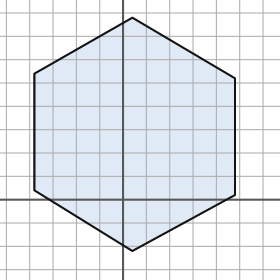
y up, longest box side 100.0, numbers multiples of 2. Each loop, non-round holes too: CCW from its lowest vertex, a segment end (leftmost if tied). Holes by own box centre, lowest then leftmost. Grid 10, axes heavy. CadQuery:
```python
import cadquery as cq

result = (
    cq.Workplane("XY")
    .moveTo(4.0, -22.0)
    .lineTo(48.0, 2.0)
    .lineTo(48.0, 52.0)
    .lineTo(4.0, 78.0)
    .lineTo(-38.0, 54.0)
    .lineTo(-38.0, 4.0)
    .close()
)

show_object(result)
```